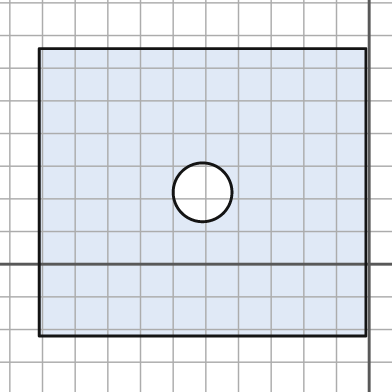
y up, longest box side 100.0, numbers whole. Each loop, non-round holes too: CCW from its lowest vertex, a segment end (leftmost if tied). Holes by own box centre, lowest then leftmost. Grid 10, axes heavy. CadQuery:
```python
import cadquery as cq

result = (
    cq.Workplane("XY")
    .moveTo(-101.0, -22.0)
    .lineTo(-1.0, -22.0)
    .lineTo(-1.0, 66.0)
    .lineTo(-101.0, 66.0)
    .close()
    .moveTo(-51.0, 22.0)
    .circle(9.0)
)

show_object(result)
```